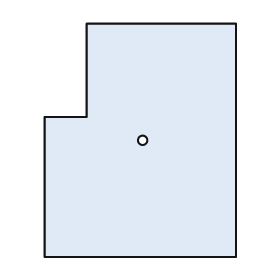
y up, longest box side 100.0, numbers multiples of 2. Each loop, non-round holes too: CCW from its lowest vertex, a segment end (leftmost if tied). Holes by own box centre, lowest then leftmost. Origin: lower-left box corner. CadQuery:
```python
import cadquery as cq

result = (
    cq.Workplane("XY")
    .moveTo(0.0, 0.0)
    .lineTo(82.0, 0.0)
    .lineTo(82.0, 100.0)
    .lineTo(18.0, 100.0)
    .lineTo(18.0, 60.0)
    .lineTo(0.0, 60.0)
    .close()
    .moveTo(42.0, 50.0)
    .circle(2.0)
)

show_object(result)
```